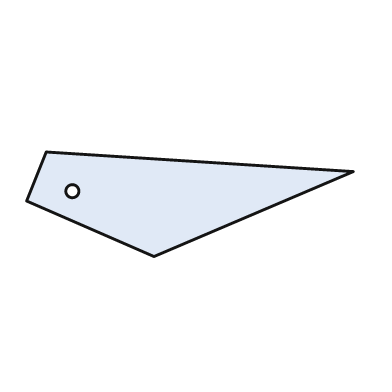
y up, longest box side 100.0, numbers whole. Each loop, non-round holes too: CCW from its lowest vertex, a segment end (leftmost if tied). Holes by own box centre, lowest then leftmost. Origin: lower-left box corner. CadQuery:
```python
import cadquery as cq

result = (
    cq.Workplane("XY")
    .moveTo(39.0, 0.0)
    .lineTo(100.0, 26.0)
    .lineTo(6.0, 32.0)
    .lineTo(0.0, 17.0)
    .close()
    .moveTo(14.0, 20.0)
    .circle(2.0)
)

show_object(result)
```